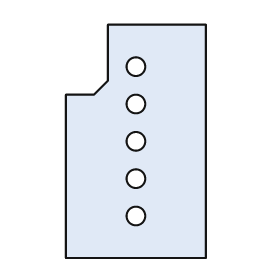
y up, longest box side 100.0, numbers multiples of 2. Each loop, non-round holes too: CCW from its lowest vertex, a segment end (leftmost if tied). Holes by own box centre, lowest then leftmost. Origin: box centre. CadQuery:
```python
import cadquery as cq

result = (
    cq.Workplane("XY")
    .moveTo(-30.0, -50.0)
    .lineTo(30.0, -50.0)
    .lineTo(30.0, 50.0)
    .lineTo(-12.0, 50.0)
    .lineTo(-12.0, 26.0)
    .lineTo(-18.0, 20.0)
    .lineTo(-30.0, 20.0)
    .close()
    .moveTo(0.0, -32.0)
    .circle(4.0)
    .moveTo(0.0, -16.0)
    .circle(4.0)
    .moveTo(0.0, 0.0)
    .circle(4.0)
    .moveTo(0.0, 16.0)
    .circle(4.0)
    .moveTo(0.0, 32.0)
    .circle(4.0)
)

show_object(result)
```